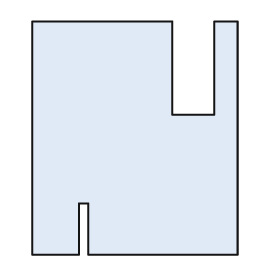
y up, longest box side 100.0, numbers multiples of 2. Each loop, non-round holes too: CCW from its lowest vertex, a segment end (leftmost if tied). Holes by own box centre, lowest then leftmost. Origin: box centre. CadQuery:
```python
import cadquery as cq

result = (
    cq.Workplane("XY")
    .moveTo(-44.0, -50.0)
    .lineTo(-24.0, -50.0)
    .lineTo(-24.0, -28.0)
    .lineTo(-20.0, -28.0)
    .lineTo(-20.0, -50.0)
    .lineTo(44.0, -50.0)
    .lineTo(44.0, 50.0)
    .lineTo(34.0, 50.0)
    .lineTo(34.0, 10.0)
    .lineTo(16.0, 10.0)
    .lineTo(16.0, 50.0)
    .lineTo(-44.0, 50.0)
    .close()
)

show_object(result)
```